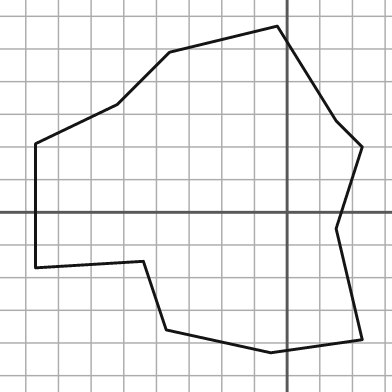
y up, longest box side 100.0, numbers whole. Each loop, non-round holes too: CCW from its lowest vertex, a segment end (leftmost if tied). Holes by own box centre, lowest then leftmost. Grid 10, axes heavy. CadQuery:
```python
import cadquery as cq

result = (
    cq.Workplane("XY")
    .moveTo(-5.0, -43.0)
    .lineTo(23.0, -39.0)
    .lineTo(15.0, -5.0)
    .lineTo(23.0, 20.0)
    .lineTo(15.0, 28.0)
    .lineTo(-3.0, 57.0)
    .lineTo(-36.0, 49.0)
    .lineTo(-52.0, 33.0)
    .lineTo(-77.0, 21.0)
    .lineTo(-77.0, -17.0)
    .lineTo(-44.0, -15.0)
    .lineTo(-37.0, -36.0)
    .close()
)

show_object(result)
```